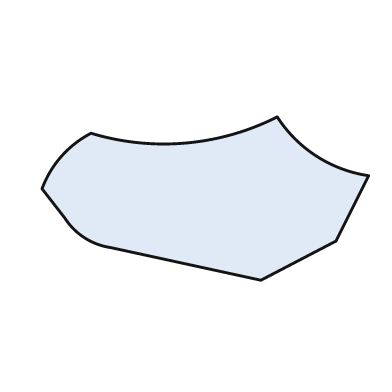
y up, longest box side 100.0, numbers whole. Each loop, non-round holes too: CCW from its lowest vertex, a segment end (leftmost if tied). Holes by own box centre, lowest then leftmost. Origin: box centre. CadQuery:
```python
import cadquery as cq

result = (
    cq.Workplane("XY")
    .moveTo(17.0, -25.0)
    .lineTo(40.0, -13.0)
    .lineTo(50.0, 7.0)
    .threePointArc((34.0, 13.0), (22.0, 25.0))
    .threePointArc((-6.0, 17.0), (-35.0, 20.0))
    .threePointArc((-44.0, 13.0), (-50.0, 3.0))
    .lineTo(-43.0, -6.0)
    .threePointArc((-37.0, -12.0), (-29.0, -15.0))
    .close()
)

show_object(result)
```